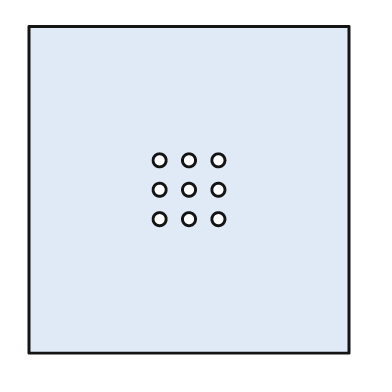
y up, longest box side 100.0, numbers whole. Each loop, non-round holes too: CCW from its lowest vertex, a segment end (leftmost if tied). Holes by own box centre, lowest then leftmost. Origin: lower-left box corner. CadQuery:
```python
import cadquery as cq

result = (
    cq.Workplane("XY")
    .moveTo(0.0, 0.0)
    .lineTo(98.0, 0.0)
    .lineTo(98.0, 100.0)
    .lineTo(0.0, 100.0)
    .close()
    .moveTo(40.0, 41.0)
    .circle(2.0)
    .moveTo(49.0, 41.0)
    .circle(2.0)
    .moveTo(58.0, 41.0)
    .circle(2.0)
    .moveTo(40.0, 50.0)
    .circle(2.0)
    .moveTo(49.0, 50.0)
    .circle(2.0)
    .moveTo(58.0, 50.0)
    .circle(2.0)
    .moveTo(40.0, 59.0)
    .circle(2.0)
    .moveTo(49.0, 59.0)
    .circle(2.0)
    .moveTo(58.0, 59.0)
    .circle(2.0)
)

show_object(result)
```